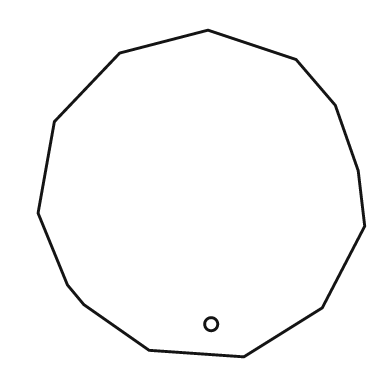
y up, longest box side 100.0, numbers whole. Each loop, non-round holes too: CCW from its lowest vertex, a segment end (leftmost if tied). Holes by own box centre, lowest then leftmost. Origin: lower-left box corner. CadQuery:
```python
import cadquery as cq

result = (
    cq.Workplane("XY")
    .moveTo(63.0, 0.0)
    .lineTo(87.0, 15.0)
    .lineTo(100.0, 40.0)
    .lineTo(98.0, 57.0)
    .lineTo(91.0, 77.0)
    .lineTo(79.0, 91.0)
    .lineTo(52.0, 100.0)
    .lineTo(25.0, 93.0)
    .lineTo(5.0, 72.0)
    .lineTo(0.0, 44.0)
    .lineTo(9.0, 22.0)
    .lineTo(14.0, 16.0)
    .lineTo(34.0, 2.0)
    .close()
    .moveTo(53.0, 10.0)
    .circle(2.0)
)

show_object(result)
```